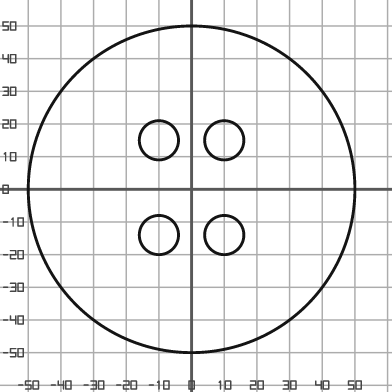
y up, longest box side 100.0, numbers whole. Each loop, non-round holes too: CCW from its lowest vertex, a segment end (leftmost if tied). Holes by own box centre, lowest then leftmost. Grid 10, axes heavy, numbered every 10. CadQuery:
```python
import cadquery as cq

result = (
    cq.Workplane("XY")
    .moveTo(0.0, 0.0)
    .circle(50.0)
    .moveTo(-10.0, -14.0)
    .circle(6.0)
    .moveTo(10.0, -14.0)
    .circle(6.0)
    .moveTo(-10.0, 15.0)
    .circle(6.0)
    .moveTo(10.0, 15.0)
    .circle(6.0)
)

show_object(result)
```